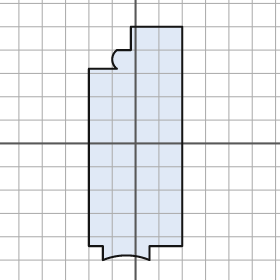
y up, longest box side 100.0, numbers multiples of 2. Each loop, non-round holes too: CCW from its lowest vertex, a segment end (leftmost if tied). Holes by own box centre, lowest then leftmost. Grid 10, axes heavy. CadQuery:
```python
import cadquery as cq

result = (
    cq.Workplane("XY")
    .moveTo(-14.0, -50.0)
    .threePointArc((-4.0, -48.0), (6.0, -50.0))
    .lineTo(6.0, -44.0)
    .lineTo(20.0, -44.0)
    .lineTo(20.0, 50.0)
    .lineTo(-2.0, 50.0)
    .lineTo(-2.0, 40.0)
    .lineTo(-8.0, 40.0)
    .threePointArc((-10.0, 36.0), (-8.0, 32.0))
    .lineTo(-20.0, 32.0)
    .lineTo(-20.0, -44.0)
    .lineTo(-14.0, -44.0)
    .close()
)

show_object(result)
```